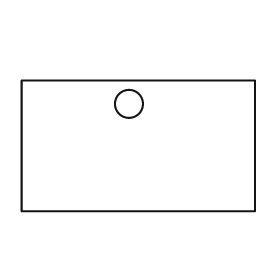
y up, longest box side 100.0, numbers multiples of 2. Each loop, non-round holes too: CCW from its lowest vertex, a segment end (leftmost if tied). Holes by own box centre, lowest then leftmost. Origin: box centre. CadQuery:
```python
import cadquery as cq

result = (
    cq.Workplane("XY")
    .moveTo(-50.0, -28.0)
    .lineTo(50.0, -28.0)
    .lineTo(50.0, 28.0)
    .lineTo(-50.0, 28.0)
    .close()
    .moveTo(-4.0, 18.0)
    .circle(6.0)
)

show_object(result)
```